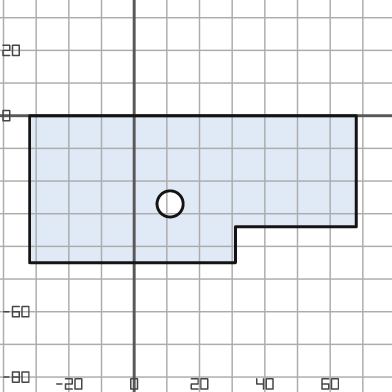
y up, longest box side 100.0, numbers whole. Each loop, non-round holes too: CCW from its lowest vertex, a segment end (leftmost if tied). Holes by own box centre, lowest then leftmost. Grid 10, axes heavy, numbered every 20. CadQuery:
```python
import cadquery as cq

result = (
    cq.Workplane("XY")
    .moveTo(-32.0, -45.0)
    .lineTo(31.0, -45.0)
    .lineTo(31.0, -34.0)
    .lineTo(68.0, -34.0)
    .lineTo(68.0, 0.0)
    .lineTo(-32.0, 0.0)
    .close()
    .moveTo(11.0, -27.0)
    .circle(4.0)
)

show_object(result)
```